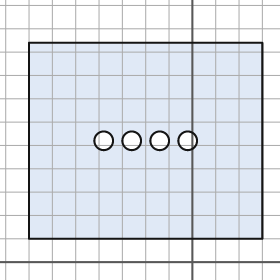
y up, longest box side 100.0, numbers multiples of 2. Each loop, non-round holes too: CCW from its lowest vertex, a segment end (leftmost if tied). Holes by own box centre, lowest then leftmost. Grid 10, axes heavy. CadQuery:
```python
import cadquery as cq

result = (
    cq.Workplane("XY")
    .moveTo(-70.0, 10.0)
    .lineTo(30.0, 10.0)
    .lineTo(30.0, 94.0)
    .lineTo(-70.0, 94.0)
    .close()
    .moveTo(-38.0, 52.0)
    .circle(4.0)
    .moveTo(-26.0, 52.0)
    .circle(4.0)
    .moveTo(-14.0, 52.0)
    .circle(4.0)
    .moveTo(-2.0, 52.0)
    .circle(4.0)
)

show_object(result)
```